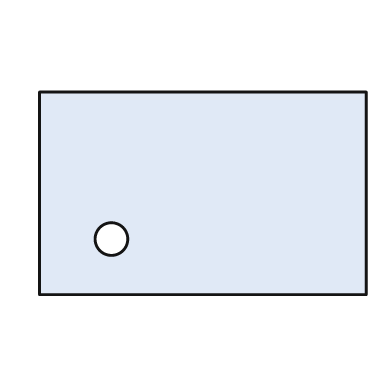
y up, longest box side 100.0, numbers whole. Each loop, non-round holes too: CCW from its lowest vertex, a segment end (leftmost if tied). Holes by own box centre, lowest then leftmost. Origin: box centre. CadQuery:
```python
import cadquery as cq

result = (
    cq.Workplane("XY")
    .moveTo(-50.0, -31.0)
    .lineTo(50.0, -31.0)
    .lineTo(50.0, 31.0)
    .lineTo(-50.0, 31.0)
    .close()
    .moveTo(-28.0, -14.0)
    .circle(5.0)
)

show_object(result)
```